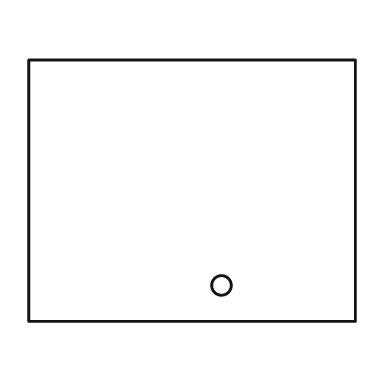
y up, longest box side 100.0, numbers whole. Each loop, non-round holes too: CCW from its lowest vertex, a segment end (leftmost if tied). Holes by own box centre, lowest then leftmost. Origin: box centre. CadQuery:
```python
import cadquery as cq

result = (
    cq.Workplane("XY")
    .moveTo(-50.0, -40.0)
    .lineTo(50.0, -40.0)
    .lineTo(50.0, 40.0)
    .lineTo(-50.0, 40.0)
    .close()
    .moveTo(9.0, -29.0)
    .circle(3.0)
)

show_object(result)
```